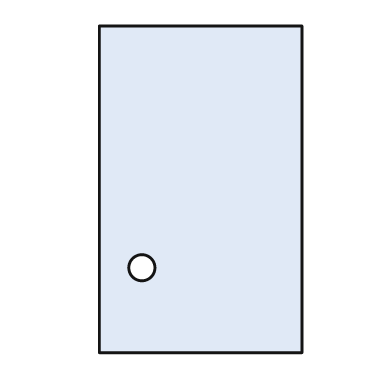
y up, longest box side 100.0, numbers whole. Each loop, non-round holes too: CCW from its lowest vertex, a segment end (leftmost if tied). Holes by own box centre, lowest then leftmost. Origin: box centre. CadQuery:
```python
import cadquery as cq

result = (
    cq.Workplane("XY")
    .moveTo(-31.0, -50.0)
    .lineTo(31.0, -50.0)
    .lineTo(31.0, 50.0)
    .lineTo(-31.0, 50.0)
    .close()
    .moveTo(-18.0, -24.0)
    .circle(4.0)
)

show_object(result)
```